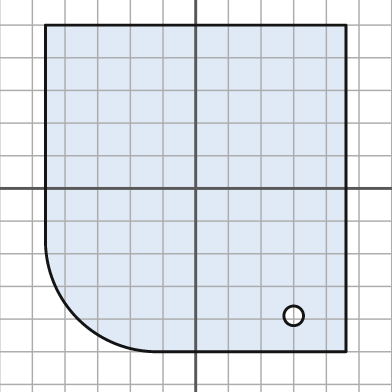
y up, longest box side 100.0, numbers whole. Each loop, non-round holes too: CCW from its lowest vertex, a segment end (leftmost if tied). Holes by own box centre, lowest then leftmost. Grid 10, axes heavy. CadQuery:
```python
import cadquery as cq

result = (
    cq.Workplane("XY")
    .moveTo(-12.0, -50.0)
    .lineTo(46.0, -50.0)
    .lineTo(46.0, 50.0)
    .lineTo(-46.0, 50.0)
    .lineTo(-46.0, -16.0)
    .threePointArc((-36.0, -40.0), (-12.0, -50.0))
    .close()
    .moveTo(30.0, -39.0)
    .circle(3.0)
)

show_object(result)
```